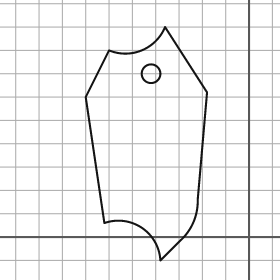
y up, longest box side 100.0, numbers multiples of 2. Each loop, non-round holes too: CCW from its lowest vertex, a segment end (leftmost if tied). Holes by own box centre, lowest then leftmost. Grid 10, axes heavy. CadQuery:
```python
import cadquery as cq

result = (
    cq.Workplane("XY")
    .moveTo(-38.0, -10.0)
    .lineTo(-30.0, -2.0)
    .threePointArc((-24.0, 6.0), (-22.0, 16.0))
    .lineTo(-18.0, 62.0)
    .lineTo(-36.0, 90.0)
    .threePointArc((-46.0, 80.0), (-60.0, 80.0))
    .lineTo(-70.0, 60.0)
    .lineTo(-62.0, 6.0)
    .threePointArc((-46.0, 4.0), (-38.0, -10.0))
    .close()
    .moveTo(-42.0, 70.0)
    .circle(4.0)
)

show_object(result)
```